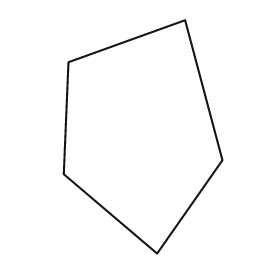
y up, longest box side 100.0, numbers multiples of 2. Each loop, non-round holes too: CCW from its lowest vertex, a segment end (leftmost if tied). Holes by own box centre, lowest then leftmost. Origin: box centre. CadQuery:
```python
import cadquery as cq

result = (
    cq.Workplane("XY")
    .moveTo(6.0, -50.0)
    .lineTo(34.0, -10.0)
    .lineTo(18.0, 50.0)
    .lineTo(-32.0, 32.0)
    .lineTo(-34.0, -16.0)
    .close()
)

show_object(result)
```